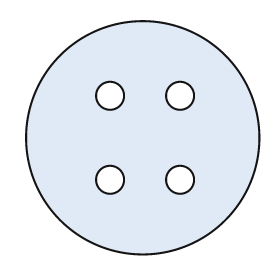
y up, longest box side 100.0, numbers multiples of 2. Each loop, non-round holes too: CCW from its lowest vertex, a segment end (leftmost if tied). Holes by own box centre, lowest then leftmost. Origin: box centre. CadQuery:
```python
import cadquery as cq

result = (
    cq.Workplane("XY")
    .moveTo(0.0, 0.0)
    .circle(50.0)
    .moveTo(-14.0, -18.0)
    .circle(6.0)
    .moveTo(16.0, -18.0)
    .circle(6.0)
    .moveTo(-14.0, 18.0)
    .circle(6.0)
    .moveTo(16.0, 18.0)
    .circle(6.0)
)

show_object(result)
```